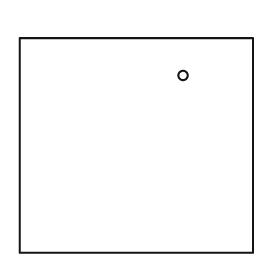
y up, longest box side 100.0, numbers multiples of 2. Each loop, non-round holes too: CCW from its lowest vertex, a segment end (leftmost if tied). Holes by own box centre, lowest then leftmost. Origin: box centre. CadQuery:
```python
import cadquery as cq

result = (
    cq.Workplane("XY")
    .moveTo(-50.0, -46.0)
    .lineTo(50.0, -46.0)
    .lineTo(50.0, 46.0)
    .lineTo(-50.0, 46.0)
    .close()
    .moveTo(20.0, 30.0)
    .circle(2.0)
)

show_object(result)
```